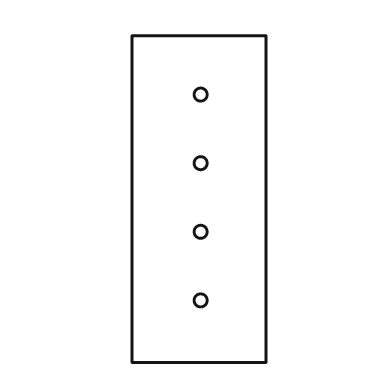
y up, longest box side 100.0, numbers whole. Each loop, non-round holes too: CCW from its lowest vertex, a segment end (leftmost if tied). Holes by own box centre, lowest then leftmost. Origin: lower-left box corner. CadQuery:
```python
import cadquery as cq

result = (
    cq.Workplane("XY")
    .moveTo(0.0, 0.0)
    .lineTo(41.0, 0.0)
    .lineTo(41.0, 100.0)
    .lineTo(0.0, 100.0)
    .close()
    .moveTo(21.0, 19.0)
    .circle(2.0)
    .moveTo(21.0, 40.0)
    .circle(2.0)
    .moveTo(21.0, 61.0)
    .circle(2.0)
    .moveTo(21.0, 82.0)
    .circle(2.0)
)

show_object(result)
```